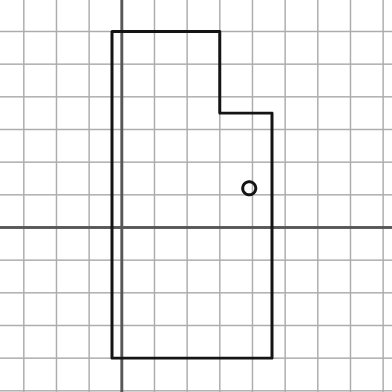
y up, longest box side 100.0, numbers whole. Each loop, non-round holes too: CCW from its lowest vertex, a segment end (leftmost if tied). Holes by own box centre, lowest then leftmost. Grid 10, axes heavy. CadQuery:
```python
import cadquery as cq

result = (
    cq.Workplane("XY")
    .moveTo(-3.0, -40.0)
    .lineTo(46.0, -40.0)
    .lineTo(46.0, 35.0)
    .lineTo(30.0, 35.0)
    .lineTo(30.0, 60.0)
    .lineTo(-3.0, 60.0)
    .close()
    .moveTo(39.0, 12.0)
    .circle(2.0)
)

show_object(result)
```